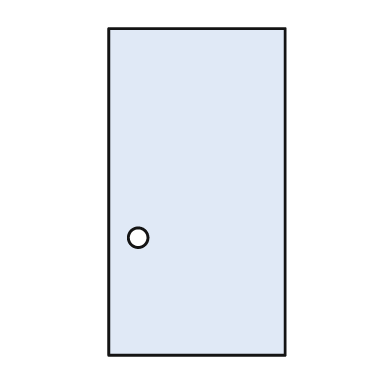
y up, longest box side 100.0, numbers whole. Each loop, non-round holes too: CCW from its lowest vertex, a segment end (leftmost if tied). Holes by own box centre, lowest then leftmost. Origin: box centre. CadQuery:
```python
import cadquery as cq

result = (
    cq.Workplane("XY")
    .moveTo(-27.0, -50.0)
    .lineTo(27.0, -50.0)
    .lineTo(27.0, 50.0)
    .lineTo(-27.0, 50.0)
    .close()
    .moveTo(-18.0, -14.0)
    .circle(3.0)
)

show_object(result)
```